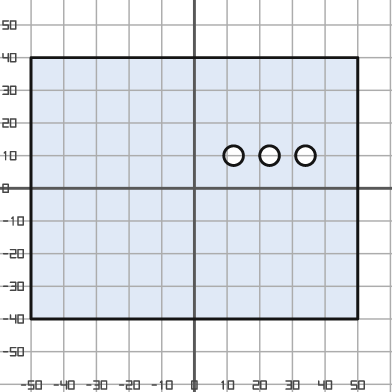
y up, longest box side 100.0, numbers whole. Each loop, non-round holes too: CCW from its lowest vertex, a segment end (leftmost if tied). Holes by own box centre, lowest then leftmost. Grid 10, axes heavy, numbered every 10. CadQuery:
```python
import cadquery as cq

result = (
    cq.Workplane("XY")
    .moveTo(-50.0, -40.0)
    .lineTo(50.0, -40.0)
    .lineTo(50.0, 40.0)
    .lineTo(-50.0, 40.0)
    .close()
    .moveTo(12.0, 10.0)
    .circle(3.0)
    .moveTo(23.0, 10.0)
    .circle(3.0)
    .moveTo(34.0, 10.0)
    .circle(3.0)
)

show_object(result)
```